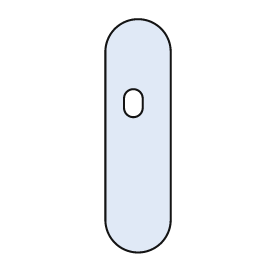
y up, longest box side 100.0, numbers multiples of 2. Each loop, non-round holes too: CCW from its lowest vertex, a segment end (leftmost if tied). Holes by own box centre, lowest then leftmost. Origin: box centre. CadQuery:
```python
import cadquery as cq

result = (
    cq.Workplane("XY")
    .moveTo(-14.0, -36.0)
    .threePointArc((0.0, -50.0), (14.0, -36.0))
    .lineTo(14.0, 36.0)
    .threePointArc((0.0, 50.0), (-14.0, 36.0))
    .close()
    .moveTo(-6.0, 12.0)
    .threePointArc((-2.0, 8.0), (2.0, 12.0))
    .lineTo(2.0, 16.0)
    .threePointArc((-2.0, 20.0), (-6.0, 16.0))
    .close()
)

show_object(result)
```